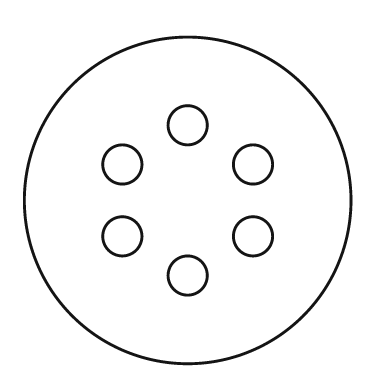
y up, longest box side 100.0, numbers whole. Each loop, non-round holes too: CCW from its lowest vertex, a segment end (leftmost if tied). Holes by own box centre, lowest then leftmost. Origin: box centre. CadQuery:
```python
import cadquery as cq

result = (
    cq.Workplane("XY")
    .moveTo(0.0, 0.0)
    .circle(50.0)
    .moveTo(0.0, -23.0)
    .circle(6.0)
    .moveTo(-20.0, -11.0)
    .circle(6.0)
    .moveTo(20.0, -11.0)
    .circle(6.0)
    .moveTo(-20.0, 11.0)
    .circle(6.0)
    .moveTo(20.0, 11.0)
    .circle(6.0)
    .moveTo(0.0, 23.0)
    .circle(6.0)
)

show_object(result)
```